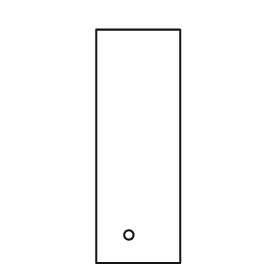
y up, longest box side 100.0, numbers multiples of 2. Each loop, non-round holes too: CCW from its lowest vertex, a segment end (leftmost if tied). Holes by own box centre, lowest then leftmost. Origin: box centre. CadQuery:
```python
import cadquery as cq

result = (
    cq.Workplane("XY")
    .moveTo(-18.0, -50.0)
    .lineTo(18.0, -50.0)
    .lineTo(18.0, 50.0)
    .lineTo(-18.0, 50.0)
    .close()
    .moveTo(-4.0, -38.0)
    .circle(2.0)
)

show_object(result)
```